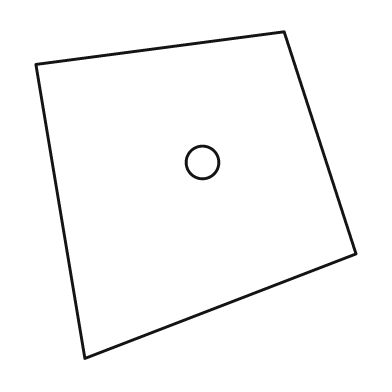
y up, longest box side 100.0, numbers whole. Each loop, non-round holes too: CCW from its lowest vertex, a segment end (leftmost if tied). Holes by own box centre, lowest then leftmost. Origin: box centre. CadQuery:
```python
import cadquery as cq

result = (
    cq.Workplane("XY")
    .moveTo(-34.0, -50.0)
    .lineTo(49.0, -18.0)
    .lineTo(27.0, 50.0)
    .lineTo(-49.0, 40.0)
    .close()
    .moveTo(2.0, 10.0)
    .circle(5.0)
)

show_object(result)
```